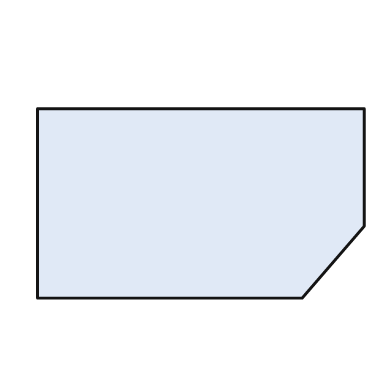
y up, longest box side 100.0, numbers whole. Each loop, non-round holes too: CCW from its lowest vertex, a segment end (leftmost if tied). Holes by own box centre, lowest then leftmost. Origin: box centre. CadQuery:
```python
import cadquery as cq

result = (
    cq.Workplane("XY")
    .moveTo(-50.0, -29.0)
    .lineTo(31.0, -29.0)
    .lineTo(50.0, -7.0)
    .lineTo(50.0, 29.0)
    .lineTo(-50.0, 29.0)
    .close()
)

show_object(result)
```